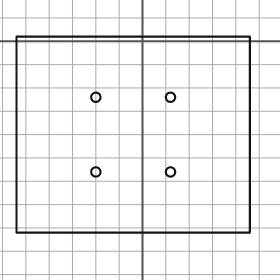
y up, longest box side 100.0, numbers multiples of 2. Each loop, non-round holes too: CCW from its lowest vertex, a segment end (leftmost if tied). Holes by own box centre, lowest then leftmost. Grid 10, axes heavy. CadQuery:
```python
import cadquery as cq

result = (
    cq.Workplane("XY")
    .moveTo(-54.0, -82.0)
    .lineTo(46.0, -82.0)
    .lineTo(46.0, 2.0)
    .lineTo(-54.0, 2.0)
    .close()
    .moveTo(-20.0, -56.0)
    .circle(2.0)
    .moveTo(12.0, -56.0)
    .circle(2.0)
    .moveTo(-20.0, -24.0)
    .circle(2.0)
    .moveTo(12.0, -24.0)
    .circle(2.0)
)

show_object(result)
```